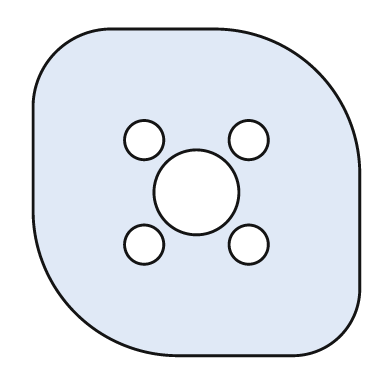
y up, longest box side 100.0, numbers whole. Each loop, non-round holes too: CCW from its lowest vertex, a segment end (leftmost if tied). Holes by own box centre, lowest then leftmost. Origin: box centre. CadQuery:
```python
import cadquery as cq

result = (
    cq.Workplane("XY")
    .moveTo(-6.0, -50.0)
    .lineTo(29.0, -50.0)
    .threePointArc((44.0, -44.0), (50.0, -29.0))
    .lineTo(50.0, 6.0)
    .threePointArc((37.0, 37.0), (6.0, 50.0))
    .lineTo(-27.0, 50.0)
    .threePointArc((-43.0, 43.0), (-50.0, 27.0))
    .lineTo(-50.0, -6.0)
    .threePointArc((-37.0, -37.0), (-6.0, -50.0))
    .close()
    .moveTo(-16.0, -16.0)
    .circle(6.0)
    .moveTo(16.0, -16.0)
    .circle(6.0)
    .moveTo(0.0, 0.0)
    .circle(13.0)
    .moveTo(-16.0, 16.0)
    .circle(6.0)
    .moveTo(16.0, 16.0)
    .circle(6.0)
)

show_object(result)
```